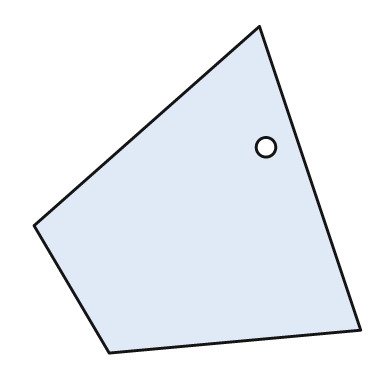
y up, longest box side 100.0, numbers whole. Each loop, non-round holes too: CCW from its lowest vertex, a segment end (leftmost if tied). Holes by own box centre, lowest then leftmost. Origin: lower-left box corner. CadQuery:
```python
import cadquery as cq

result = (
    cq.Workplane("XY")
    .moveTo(23.0, 0.0)
    .lineTo(100.0, 7.0)
    .lineTo(69.0, 100.0)
    .lineTo(0.0, 39.0)
    .close()
    .moveTo(71.0, 63.0)
    .circle(3.0)
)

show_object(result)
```